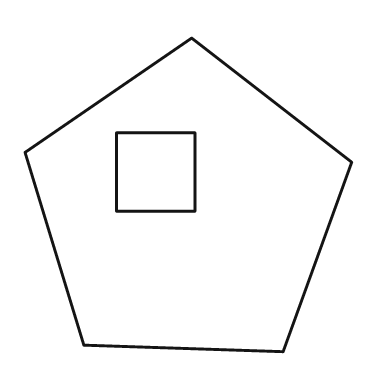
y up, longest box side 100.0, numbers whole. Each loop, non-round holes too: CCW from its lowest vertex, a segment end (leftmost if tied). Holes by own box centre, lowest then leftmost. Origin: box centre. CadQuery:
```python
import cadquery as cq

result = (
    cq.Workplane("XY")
    .moveTo(29.0, -48.0)
    .lineTo(50.0, 10.0)
    .lineTo(1.0, 48.0)
    .lineTo(-50.0, 13.0)
    .lineTo(-32.0, -46.0)
    .close()
    .moveTo(-22.0, -5.0)
    .lineTo(2.0, -5.0)
    .lineTo(2.0, 19.0)
    .lineTo(-22.0, 19.0)
    .close()
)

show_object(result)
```